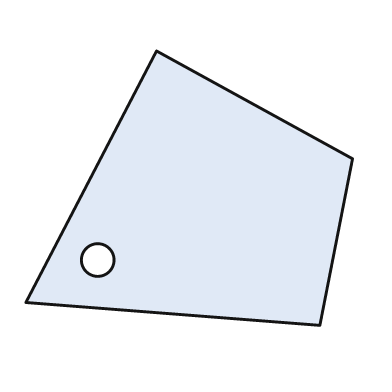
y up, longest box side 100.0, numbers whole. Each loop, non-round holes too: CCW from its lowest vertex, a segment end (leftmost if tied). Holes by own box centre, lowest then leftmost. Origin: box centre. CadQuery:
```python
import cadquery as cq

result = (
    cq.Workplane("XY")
    .moveTo(40.0, -42.0)
    .lineTo(50.0, 9.0)
    .lineTo(-10.0, 42.0)
    .lineTo(-50.0, -35.0)
    .close()
    .moveTo(-28.0, -22.0)
    .circle(5.0)
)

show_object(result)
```